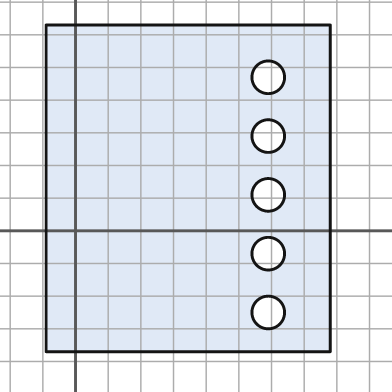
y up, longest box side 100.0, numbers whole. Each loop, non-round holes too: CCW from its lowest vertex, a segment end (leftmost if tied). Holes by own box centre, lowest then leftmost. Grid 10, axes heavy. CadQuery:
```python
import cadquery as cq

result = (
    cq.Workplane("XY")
    .moveTo(-9.0, -37.0)
    .lineTo(78.0, -37.0)
    .lineTo(78.0, 63.0)
    .lineTo(-9.0, 63.0)
    .close()
    .moveTo(59.0, -25.0)
    .circle(5.0)
    .moveTo(59.0, -7.0)
    .circle(5.0)
    .moveTo(59.0, 11.0)
    .circle(5.0)
    .moveTo(59.0, 29.0)
    .circle(5.0)
    .moveTo(59.0, 47.0)
    .circle(5.0)
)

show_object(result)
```